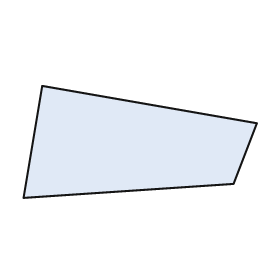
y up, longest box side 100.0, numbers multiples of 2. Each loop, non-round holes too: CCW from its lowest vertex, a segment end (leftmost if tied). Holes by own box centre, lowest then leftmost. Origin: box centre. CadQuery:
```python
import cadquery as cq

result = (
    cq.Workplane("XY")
    .moveTo(-50.0, -24.0)
    .lineTo(40.0, -18.0)
    .lineTo(50.0, 8.0)
    .lineTo(-42.0, 24.0)
    .close()
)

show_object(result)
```